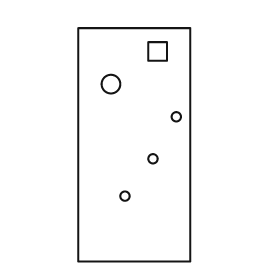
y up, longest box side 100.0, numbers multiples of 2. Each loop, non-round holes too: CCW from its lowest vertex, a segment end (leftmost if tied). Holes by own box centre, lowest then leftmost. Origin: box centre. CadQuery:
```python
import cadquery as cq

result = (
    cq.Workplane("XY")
    .moveTo(-24.0, -50.0)
    .lineTo(24.0, -50.0)
    .lineTo(24.0, 50.0)
    .lineTo(-24.0, 50.0)
    .close()
    .moveTo(-4.0, -22.0)
    .circle(2.0)
    .moveTo(8.0, -6.0)
    .circle(2.0)
    .moveTo(18.0, 12.0)
    .circle(2.0)
    .moveTo(-10.0, 26.0)
    .circle(4.0)
    .moveTo(6.0, 36.0)
    .lineTo(14.0, 36.0)
    .lineTo(14.0, 44.0)
    .lineTo(6.0, 44.0)
    .close()
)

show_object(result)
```